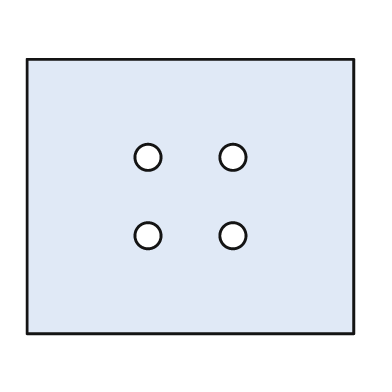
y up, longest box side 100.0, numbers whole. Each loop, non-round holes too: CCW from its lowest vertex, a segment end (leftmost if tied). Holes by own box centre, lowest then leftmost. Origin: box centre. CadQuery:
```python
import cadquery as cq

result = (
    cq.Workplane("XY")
    .moveTo(-50.0, -42.0)
    .lineTo(50.0, -42.0)
    .lineTo(50.0, 42.0)
    .lineTo(-50.0, 42.0)
    .close()
    .moveTo(-13.0, -12.0)
    .circle(4.0)
    .moveTo(13.0, -12.0)
    .circle(4.0)
    .moveTo(-13.0, 12.0)
    .circle(4.0)
    .moveTo(13.0, 12.0)
    .circle(4.0)
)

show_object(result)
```